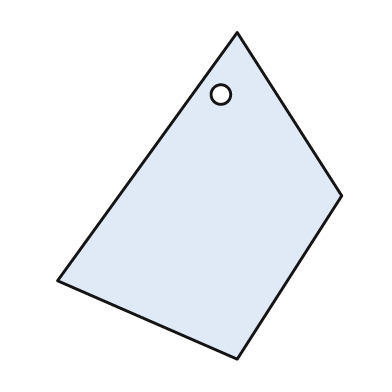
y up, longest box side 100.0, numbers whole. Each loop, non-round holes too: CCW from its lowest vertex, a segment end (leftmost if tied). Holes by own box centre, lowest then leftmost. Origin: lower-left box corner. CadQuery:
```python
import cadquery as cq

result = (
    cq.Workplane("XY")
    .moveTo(55.0, 0.0)
    .lineTo(87.0, 50.0)
    .lineTo(55.0, 100.0)
    .lineTo(0.0, 24.0)
    .close()
    .moveTo(50.0, 81.0)
    .circle(3.0)
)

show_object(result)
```